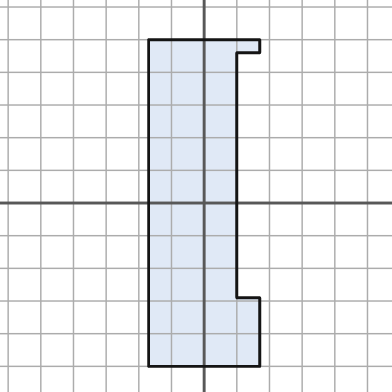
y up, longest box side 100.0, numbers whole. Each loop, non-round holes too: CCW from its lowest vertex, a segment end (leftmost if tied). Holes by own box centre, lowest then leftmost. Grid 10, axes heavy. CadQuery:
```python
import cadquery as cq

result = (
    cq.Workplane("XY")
    .moveTo(-17.0, -50.0)
    .lineTo(17.0, -50.0)
    .lineTo(17.0, -29.0)
    .lineTo(10.0, -29.0)
    .lineTo(10.0, 46.0)
    .lineTo(17.0, 46.0)
    .lineTo(17.0, 50.0)
    .lineTo(-17.0, 50.0)
    .close()
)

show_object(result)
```